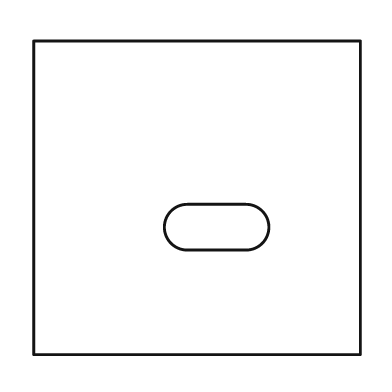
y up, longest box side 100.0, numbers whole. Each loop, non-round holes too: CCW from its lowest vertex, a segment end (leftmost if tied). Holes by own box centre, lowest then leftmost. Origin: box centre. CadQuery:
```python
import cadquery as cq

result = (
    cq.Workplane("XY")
    .moveTo(-50.0, -48.0)
    .lineTo(50.0, -48.0)
    .lineTo(50.0, 48.0)
    .lineTo(-50.0, 48.0)
    .close()
    .moveTo(-3.0, -16.0)
    .lineTo(15.0, -16.0)
    .threePointArc((22.0, -9.0), (15.0, -2.0))
    .lineTo(-3.0, -2.0)
    .threePointArc((-10.0, -9.0), (-3.0, -16.0))
    .close()
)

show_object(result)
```